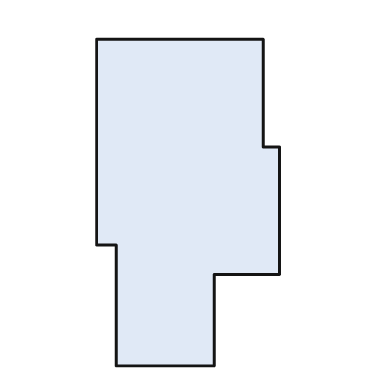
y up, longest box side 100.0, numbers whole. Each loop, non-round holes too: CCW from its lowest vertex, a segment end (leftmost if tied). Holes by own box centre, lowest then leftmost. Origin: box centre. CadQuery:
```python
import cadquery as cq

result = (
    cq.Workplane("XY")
    .moveTo(-22.0, -50.0)
    .lineTo(8.0, -50.0)
    .lineTo(8.0, -22.0)
    .lineTo(28.0, -22.0)
    .lineTo(28.0, 17.0)
    .lineTo(23.0, 17.0)
    .lineTo(23.0, 50.0)
    .lineTo(-28.0, 50.0)
    .lineTo(-28.0, -13.0)
    .lineTo(-22.0, -13.0)
    .close()
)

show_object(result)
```